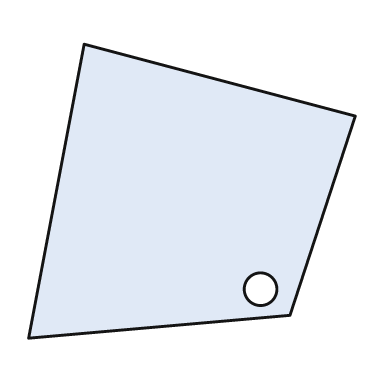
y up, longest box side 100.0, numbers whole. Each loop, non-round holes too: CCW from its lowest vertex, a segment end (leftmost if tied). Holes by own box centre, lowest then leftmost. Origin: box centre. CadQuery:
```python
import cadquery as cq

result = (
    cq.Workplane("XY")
    .moveTo(-50.0, -45.0)
    .lineTo(30.0, -38.0)
    .lineTo(50.0, 23.0)
    .lineTo(-33.0, 45.0)
    .close()
    .moveTo(21.0, -30.0)
    .circle(5.0)
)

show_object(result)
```